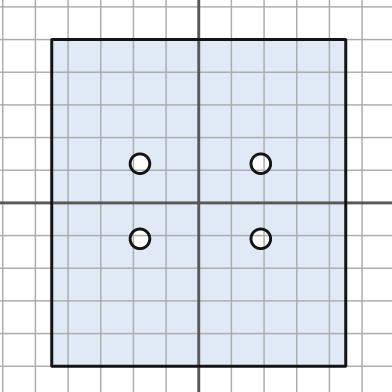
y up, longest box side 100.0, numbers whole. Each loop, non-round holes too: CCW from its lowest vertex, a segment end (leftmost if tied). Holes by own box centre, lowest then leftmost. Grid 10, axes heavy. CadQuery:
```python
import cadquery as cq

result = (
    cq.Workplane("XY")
    .moveTo(-45.0, -50.0)
    .lineTo(45.0, -50.0)
    .lineTo(45.0, 50.0)
    .lineTo(-45.0, 50.0)
    .close()
    .moveTo(-18.0, -11.0)
    .circle(3.0)
    .moveTo(19.0, -11.0)
    .circle(3.0)
    .moveTo(-18.0, 12.0)
    .circle(3.0)
    .moveTo(19.0, 12.0)
    .circle(3.0)
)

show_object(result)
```